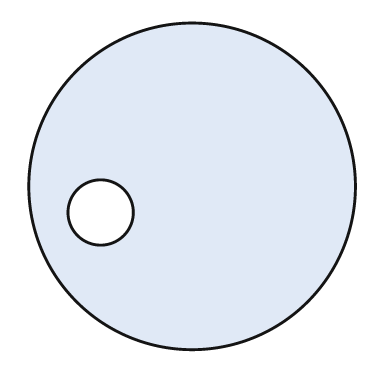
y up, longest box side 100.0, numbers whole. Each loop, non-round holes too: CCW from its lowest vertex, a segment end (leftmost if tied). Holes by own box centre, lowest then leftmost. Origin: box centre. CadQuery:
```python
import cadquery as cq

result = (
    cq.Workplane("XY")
    .moveTo(0.0, 0.0)
    .circle(50.0)
    .moveTo(-28.0, -8.0)
    .circle(10.0)
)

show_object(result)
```